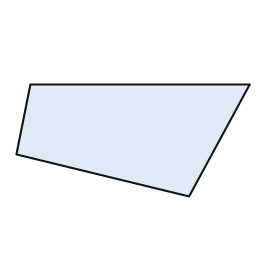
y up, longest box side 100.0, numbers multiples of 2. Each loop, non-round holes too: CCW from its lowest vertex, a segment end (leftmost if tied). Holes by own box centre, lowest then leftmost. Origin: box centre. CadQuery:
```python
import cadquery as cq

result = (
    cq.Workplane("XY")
    .moveTo(24.0, -24.0)
    .lineTo(50.0, 24.0)
    .lineTo(-44.0, 24.0)
    .lineTo(-50.0, -6.0)
    .close()
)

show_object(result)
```